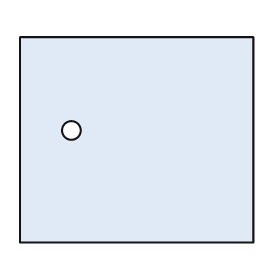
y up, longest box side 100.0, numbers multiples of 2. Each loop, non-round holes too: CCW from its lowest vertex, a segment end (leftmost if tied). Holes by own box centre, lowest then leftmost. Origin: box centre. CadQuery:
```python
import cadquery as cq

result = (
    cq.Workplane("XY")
    .moveTo(-50.0, -44.0)
    .lineTo(50.0, -44.0)
    .lineTo(50.0, 44.0)
    .lineTo(-50.0, 44.0)
    .close()
    .moveTo(-28.0, 4.0)
    .circle(4.0)
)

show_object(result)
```